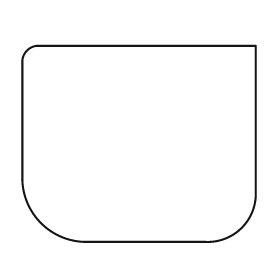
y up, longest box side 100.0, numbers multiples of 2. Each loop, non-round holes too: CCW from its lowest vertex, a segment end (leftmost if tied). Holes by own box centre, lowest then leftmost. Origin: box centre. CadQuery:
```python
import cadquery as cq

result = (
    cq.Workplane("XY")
    .moveTo(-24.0, -42.0)
    .lineTo(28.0, -42.0)
    .threePointArc((44.0, -36.0), (50.0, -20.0))
    .lineTo(50.0, 42.0)
    .lineTo(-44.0, 42.0)
    .threePointArc((-48.0, 40.0), (-50.0, 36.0))
    .lineTo(-50.0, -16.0)
    .threePointArc((-42.0, -34.0), (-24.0, -42.0))
    .close()
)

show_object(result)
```